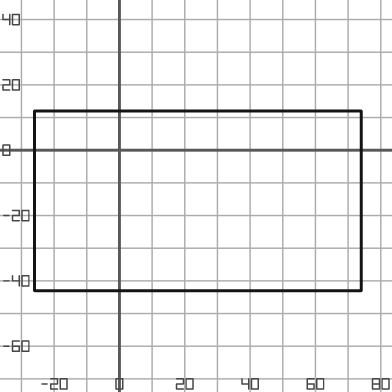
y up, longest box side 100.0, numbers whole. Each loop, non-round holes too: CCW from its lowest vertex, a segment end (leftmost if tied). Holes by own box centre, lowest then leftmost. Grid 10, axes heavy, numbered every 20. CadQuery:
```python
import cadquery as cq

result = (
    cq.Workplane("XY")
    .moveTo(-26.0, -43.0)
    .lineTo(74.0, -43.0)
    .lineTo(74.0, 12.0)
    .lineTo(-26.0, 12.0)
    .close()
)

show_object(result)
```